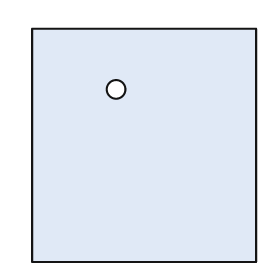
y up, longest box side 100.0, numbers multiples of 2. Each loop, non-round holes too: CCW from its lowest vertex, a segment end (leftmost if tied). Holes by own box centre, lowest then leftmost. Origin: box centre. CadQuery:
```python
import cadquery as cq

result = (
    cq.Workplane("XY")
    .moveTo(-48.0, -50.0)
    .lineTo(48.0, -50.0)
    .lineTo(48.0, 50.0)
    .lineTo(-48.0, 50.0)
    .close()
    .moveTo(-12.0, 24.0)
    .circle(4.0)
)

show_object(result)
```